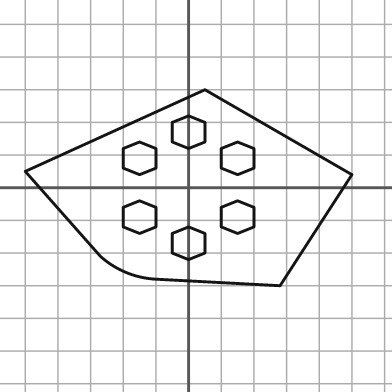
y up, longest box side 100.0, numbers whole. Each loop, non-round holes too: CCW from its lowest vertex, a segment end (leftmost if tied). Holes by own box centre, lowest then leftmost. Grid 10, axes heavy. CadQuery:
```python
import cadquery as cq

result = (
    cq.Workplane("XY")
    .moveTo(28.0, -30.0)
    .lineTo(50.0, 4.0)
    .lineTo(5.0, 30.0)
    .lineTo(-50.0, 5.0)
    .lineTo(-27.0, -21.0)
    .threePointArc((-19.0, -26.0), (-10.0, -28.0))
    .close()
    .moveTo(0.0, -22.0)
    .lineTo(5.0, -20.0)
    .lineTo(5.0, -14.0)
    .lineTo(0.0, -12.0)
    .lineTo(-5.0, -14.0)
    .lineTo(-5.0, -20.0)
    .close()
    .moveTo(-15.0, -14.0)
    .lineTo(-10.0, -12.0)
    .lineTo(-10.0, -6.0)
    .lineTo(-15.0, -4.0)
    .lineTo(-20.0, -6.0)
    .lineTo(-20.0, -12.0)
    .close()
    .moveTo(15.0, -14.0)
    .lineTo(20.0, -12.0)
    .lineTo(20.0, -6.0)
    .lineTo(15.0, -4.0)
    .lineTo(10.0, -6.0)
    .lineTo(10.0, -12.0)
    .close()
    .moveTo(-15.0, 4.0)
    .lineTo(-10.0, 6.0)
    .lineTo(-10.0, 12.0)
    .lineTo(-15.0, 14.0)
    .lineTo(-20.0, 12.0)
    .lineTo(-20.0, 6.0)
    .close()
    .moveTo(15.0, 4.0)
    .lineTo(20.0, 6.0)
    .lineTo(20.0, 12.0)
    .lineTo(15.0, 14.0)
    .lineTo(10.0, 12.0)
    .lineTo(10.0, 6.0)
    .close()
    .moveTo(0.0, 12.0)
    .lineTo(5.0, 14.0)
    .lineTo(5.0, 20.0)
    .lineTo(0.0, 22.0)
    .lineTo(-5.0, 20.0)
    .lineTo(-5.0, 14.0)
    .close()
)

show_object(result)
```